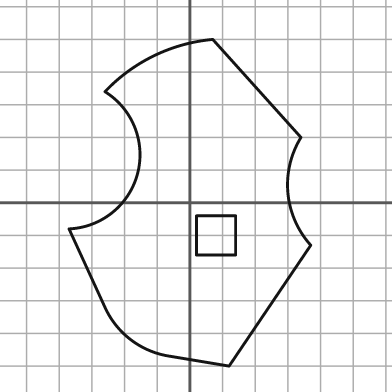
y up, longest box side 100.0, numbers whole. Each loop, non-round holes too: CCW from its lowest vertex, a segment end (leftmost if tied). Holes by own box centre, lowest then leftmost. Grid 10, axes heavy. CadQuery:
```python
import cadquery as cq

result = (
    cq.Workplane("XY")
    .moveTo(12.0, -50.0)
    .lineTo(37.0, -13.0)
    .threePointArc((30.0, 3.0), (34.0, 20.0))
    .lineTo(7.0, 50.0)
    .threePointArc((-11.0, 45.0), (-26.0, 34.0))
    .threePointArc((-16.0, 9.0), (-37.0, -8.0))
    .lineTo(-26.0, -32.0)
    .threePointArc((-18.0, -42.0), (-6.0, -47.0))
    .close()
    .moveTo(2.0, -16.0)
    .lineTo(14.0, -16.0)
    .lineTo(14.0, -4.0)
    .lineTo(2.0, -4.0)
    .close()
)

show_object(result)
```